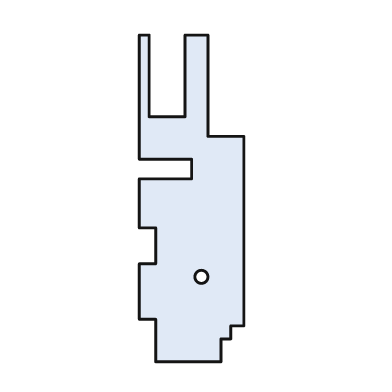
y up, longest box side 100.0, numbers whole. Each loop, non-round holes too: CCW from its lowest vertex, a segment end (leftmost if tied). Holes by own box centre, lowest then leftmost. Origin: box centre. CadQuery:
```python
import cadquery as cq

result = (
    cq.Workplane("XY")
    .moveTo(-11.0, -50.0)
    .lineTo(9.0, -50.0)
    .lineTo(9.0, -43.0)
    .lineTo(12.0, -43.0)
    .lineTo(12.0, -39.0)
    .lineTo(16.0, -39.0)
    .lineTo(16.0, 19.0)
    .lineTo(5.0, 19.0)
    .lineTo(5.0, 50.0)
    .lineTo(-2.0, 50.0)
    .lineTo(-2.0, 25.0)
    .lineTo(-13.0, 25.0)
    .lineTo(-13.0, 50.0)
    .lineTo(-16.0, 50.0)
    .lineTo(-16.0, 12.0)
    .lineTo(0.0, 12.0)
    .lineTo(0.0, 6.0)
    .lineTo(-16.0, 6.0)
    .lineTo(-16.0, -9.0)
    .lineTo(-11.0, -9.0)
    .lineTo(-11.0, -20.0)
    .lineTo(-16.0, -20.0)
    .lineTo(-16.0, -37.0)
    .lineTo(-11.0, -37.0)
    .close()
    .moveTo(3.0, -24.0)
    .circle(2.0)
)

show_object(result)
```